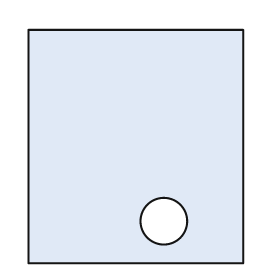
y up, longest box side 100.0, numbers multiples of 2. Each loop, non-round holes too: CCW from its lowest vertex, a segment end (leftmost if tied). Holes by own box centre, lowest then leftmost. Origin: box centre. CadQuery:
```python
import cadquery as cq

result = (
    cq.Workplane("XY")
    .moveTo(-46.0, -50.0)
    .lineTo(46.0, -50.0)
    .lineTo(46.0, 50.0)
    .lineTo(-46.0, 50.0)
    .close()
    .moveTo(12.0, -32.0)
    .circle(10.0)
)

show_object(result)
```